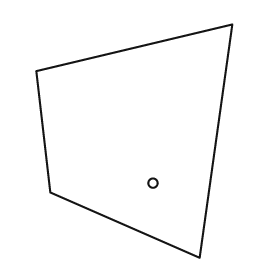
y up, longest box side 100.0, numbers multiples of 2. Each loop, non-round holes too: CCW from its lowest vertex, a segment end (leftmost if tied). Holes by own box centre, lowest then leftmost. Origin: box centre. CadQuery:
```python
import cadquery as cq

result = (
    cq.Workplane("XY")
    .moveTo(28.0, -50.0)
    .lineTo(42.0, 50.0)
    .lineTo(-42.0, 30.0)
    .lineTo(-36.0, -22.0)
    .close()
    .moveTo(8.0, -18.0)
    .circle(2.0)
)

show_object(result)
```